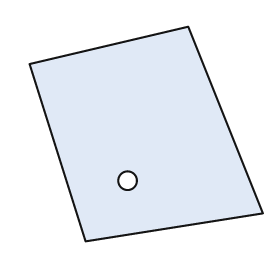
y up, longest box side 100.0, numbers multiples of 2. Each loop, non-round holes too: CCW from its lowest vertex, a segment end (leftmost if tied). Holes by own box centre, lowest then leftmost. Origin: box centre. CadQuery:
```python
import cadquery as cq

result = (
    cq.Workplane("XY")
    .moveTo(-26.0, -46.0)
    .lineTo(50.0, -34.0)
    .lineTo(18.0, 46.0)
    .lineTo(-50.0, 30.0)
    .close()
    .moveTo(-8.0, -20.0)
    .circle(4.0)
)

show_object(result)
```